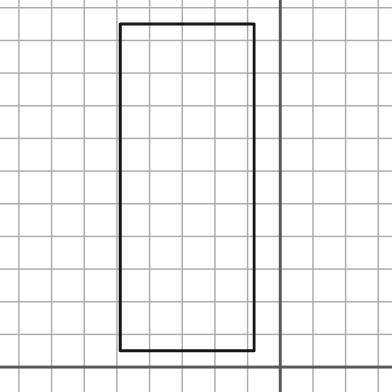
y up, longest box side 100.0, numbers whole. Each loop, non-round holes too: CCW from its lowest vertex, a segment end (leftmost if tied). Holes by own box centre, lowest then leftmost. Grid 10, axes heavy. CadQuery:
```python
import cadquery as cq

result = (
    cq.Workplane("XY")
    .moveTo(-49.0, 5.0)
    .lineTo(-8.0, 5.0)
    .lineTo(-8.0, 105.0)
    .lineTo(-49.0, 105.0)
    .close()
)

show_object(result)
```